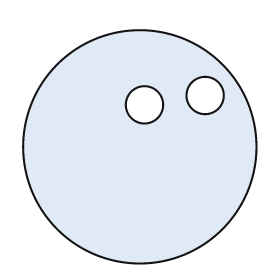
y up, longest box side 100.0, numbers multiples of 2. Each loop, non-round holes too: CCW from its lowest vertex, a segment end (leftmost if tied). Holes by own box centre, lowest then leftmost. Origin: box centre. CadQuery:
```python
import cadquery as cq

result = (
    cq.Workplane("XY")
    .moveTo(0.0, 0.0)
    .circle(50.0)
    .moveTo(2.0, 18.0)
    .circle(8.0)
    .moveTo(28.0, 22.0)
    .circle(8.0)
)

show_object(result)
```